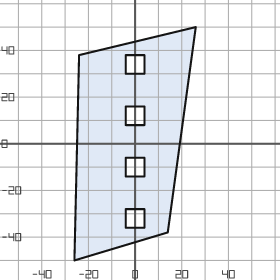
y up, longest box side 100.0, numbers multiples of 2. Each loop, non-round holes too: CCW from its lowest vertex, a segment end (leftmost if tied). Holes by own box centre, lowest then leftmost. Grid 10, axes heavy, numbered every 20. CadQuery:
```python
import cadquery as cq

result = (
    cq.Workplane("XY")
    .moveTo(-26.0, -50.0)
    .lineTo(14.0, -38.0)
    .lineTo(26.0, 50.0)
    .lineTo(-24.0, 38.0)
    .close()
    .moveTo(-4.0, -36.0)
    .lineTo(4.0, -36.0)
    .lineTo(4.0, -28.0)
    .lineTo(-4.0, -28.0)
    .close()
    .moveTo(-4.0, -14.0)
    .lineTo(4.0, -14.0)
    .lineTo(4.0, -6.0)
    .lineTo(-4.0, -6.0)
    .close()
    .moveTo(-4.0, 8.0)
    .lineTo(4.0, 8.0)
    .lineTo(4.0, 16.0)
    .lineTo(-4.0, 16.0)
    .close()
    .moveTo(-4.0, 30.0)
    .lineTo(4.0, 30.0)
    .lineTo(4.0, 38.0)
    .lineTo(-4.0, 38.0)
    .close()
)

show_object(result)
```